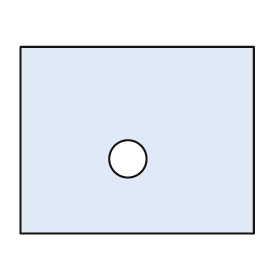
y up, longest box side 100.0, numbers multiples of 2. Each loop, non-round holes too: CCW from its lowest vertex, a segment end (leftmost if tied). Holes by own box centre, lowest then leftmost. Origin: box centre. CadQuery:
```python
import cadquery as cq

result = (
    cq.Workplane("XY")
    .moveTo(-50.0, -40.0)
    .lineTo(50.0, -40.0)
    .lineTo(50.0, 40.0)
    .lineTo(-50.0, 40.0)
    .close()
    .moveTo(-4.0, -8.0)
    .circle(8.0)
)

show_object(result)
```